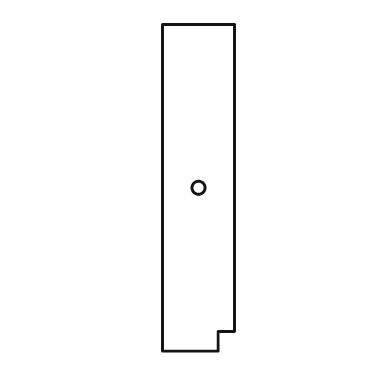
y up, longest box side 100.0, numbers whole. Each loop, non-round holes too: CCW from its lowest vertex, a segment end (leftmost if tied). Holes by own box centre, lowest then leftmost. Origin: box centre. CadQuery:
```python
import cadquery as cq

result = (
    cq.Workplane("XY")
    .moveTo(-11.0, -50.0)
    .lineTo(6.0, -50.0)
    .lineTo(6.0, -44.0)
    .lineTo(11.0, -44.0)
    .lineTo(11.0, 50.0)
    .lineTo(-11.0, 50.0)
    .close()
    .moveTo(0.0, 0.0)
    .circle(2.0)
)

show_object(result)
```